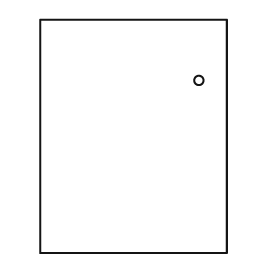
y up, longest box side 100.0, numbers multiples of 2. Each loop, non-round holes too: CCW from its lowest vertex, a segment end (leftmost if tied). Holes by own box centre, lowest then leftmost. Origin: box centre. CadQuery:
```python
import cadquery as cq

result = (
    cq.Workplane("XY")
    .moveTo(-40.0, -50.0)
    .lineTo(40.0, -50.0)
    .lineTo(40.0, 50.0)
    .lineTo(-40.0, 50.0)
    .close()
    .moveTo(28.0, 24.0)
    .circle(2.0)
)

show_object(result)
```